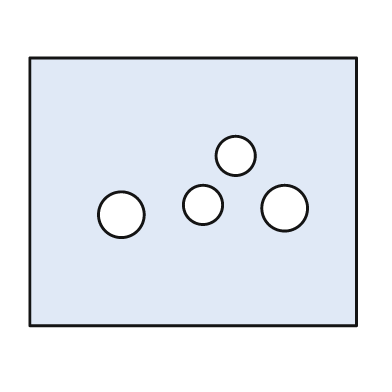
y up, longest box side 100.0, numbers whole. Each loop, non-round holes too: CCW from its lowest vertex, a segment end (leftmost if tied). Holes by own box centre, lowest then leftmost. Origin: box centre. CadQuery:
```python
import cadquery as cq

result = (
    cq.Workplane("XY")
    .moveTo(-50.0, -41.0)
    .lineTo(50.0, -41.0)
    .lineTo(50.0, 41.0)
    .lineTo(-50.0, 41.0)
    .close()
    .moveTo(-22.0, -7.0)
    .circle(7.0)
    .moveTo(28.0, -5.0)
    .circle(7.0)
    .moveTo(3.0, -4.0)
    .circle(6.0)
    .moveTo(13.0, 11.0)
    .circle(6.0)
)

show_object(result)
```